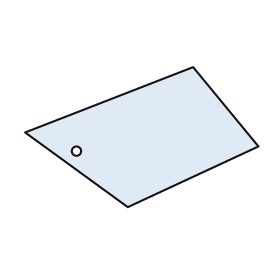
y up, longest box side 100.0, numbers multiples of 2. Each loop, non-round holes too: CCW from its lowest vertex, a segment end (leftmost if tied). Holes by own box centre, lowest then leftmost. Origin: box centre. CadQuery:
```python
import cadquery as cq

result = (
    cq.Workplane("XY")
    .moveTo(-6.0, -30.0)
    .lineTo(50.0, -4.0)
    .lineTo(22.0, 30.0)
    .lineTo(-50.0, 2.0)
    .close()
    .moveTo(-28.0, -6.0)
    .circle(2.0)
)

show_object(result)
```